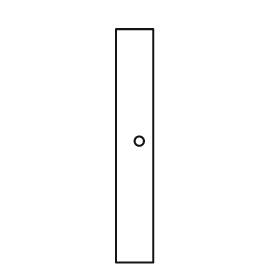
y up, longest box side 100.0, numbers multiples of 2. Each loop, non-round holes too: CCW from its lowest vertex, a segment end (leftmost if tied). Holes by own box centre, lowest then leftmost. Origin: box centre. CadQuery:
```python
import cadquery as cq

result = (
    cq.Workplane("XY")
    .moveTo(-8.0, -50.0)
    .lineTo(8.0, -50.0)
    .lineTo(8.0, 50.0)
    .lineTo(-8.0, 50.0)
    .close()
    .moveTo(2.0, 2.0)
    .circle(2.0)
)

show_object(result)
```